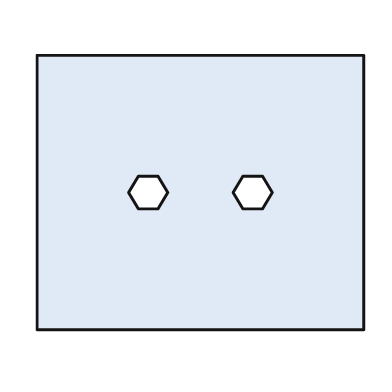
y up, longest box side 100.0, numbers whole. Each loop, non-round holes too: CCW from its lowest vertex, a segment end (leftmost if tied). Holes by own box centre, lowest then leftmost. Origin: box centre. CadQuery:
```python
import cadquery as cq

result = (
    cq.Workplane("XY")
    .moveTo(-50.0, -42.0)
    .lineTo(50.0, -42.0)
    .lineTo(50.0, 42.0)
    .lineTo(-50.0, 42.0)
    .close()
    .moveTo(-19.0, -5.0)
    .lineTo(-13.0, -5.0)
    .lineTo(-10.0, 0.0)
    .lineTo(-13.0, 5.0)
    .lineTo(-19.0, 5.0)
    .lineTo(-22.0, 0.0)
    .close()
    .moveTo(13.0, -5.0)
    .lineTo(19.0, -5.0)
    .lineTo(22.0, 0.0)
    .lineTo(19.0, 5.0)
    .lineTo(13.0, 5.0)
    .lineTo(10.0, 0.0)
    .close()
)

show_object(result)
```